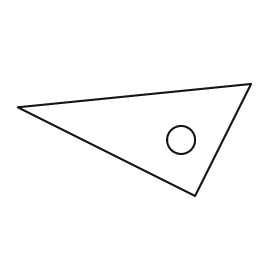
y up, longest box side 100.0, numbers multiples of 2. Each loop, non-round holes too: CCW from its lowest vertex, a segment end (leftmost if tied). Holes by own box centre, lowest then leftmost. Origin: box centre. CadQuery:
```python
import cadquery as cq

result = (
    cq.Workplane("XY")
    .moveTo(26.0, -24.0)
    .lineTo(50.0, 24.0)
    .lineTo(-50.0, 14.0)
    .close()
    .moveTo(20.0, 0.0)
    .circle(6.0)
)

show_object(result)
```